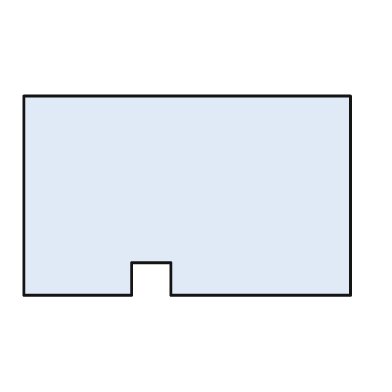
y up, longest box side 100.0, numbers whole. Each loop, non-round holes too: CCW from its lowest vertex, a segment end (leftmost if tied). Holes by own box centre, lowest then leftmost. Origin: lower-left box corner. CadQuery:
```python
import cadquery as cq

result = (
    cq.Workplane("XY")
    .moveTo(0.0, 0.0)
    .lineTo(33.0, 0.0)
    .lineTo(33.0, 10.0)
    .lineTo(45.0, 10.0)
    .lineTo(45.0, 0.0)
    .lineTo(100.0, 0.0)
    .lineTo(100.0, 61.0)
    .lineTo(0.0, 61.0)
    .close()
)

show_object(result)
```